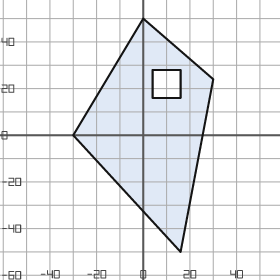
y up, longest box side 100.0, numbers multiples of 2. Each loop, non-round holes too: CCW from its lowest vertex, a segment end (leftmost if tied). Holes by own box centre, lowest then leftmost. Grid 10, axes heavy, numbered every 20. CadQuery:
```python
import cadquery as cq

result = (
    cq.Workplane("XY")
    .moveTo(16.0, -50.0)
    .lineTo(30.0, 24.0)
    .lineTo(0.0, 50.0)
    .lineTo(-30.0, 0.0)
    .close()
    .moveTo(4.0, 16.0)
    .lineTo(16.0, 16.0)
    .lineTo(16.0, 28.0)
    .lineTo(4.0, 28.0)
    .close()
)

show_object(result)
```